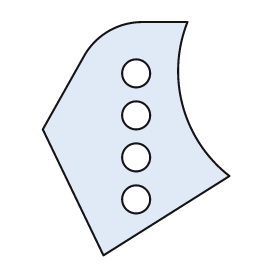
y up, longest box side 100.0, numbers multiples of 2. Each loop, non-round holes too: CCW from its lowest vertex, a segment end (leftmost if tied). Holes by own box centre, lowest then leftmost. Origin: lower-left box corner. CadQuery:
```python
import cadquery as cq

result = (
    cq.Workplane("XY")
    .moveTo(26.0, 0.0)
    .lineTo(80.0, 34.0)
    .threePointArc((60.0, 64.0), (62.0, 100.0))
    .lineTo(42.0, 100.0)
    .threePointArc((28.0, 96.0), (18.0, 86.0))
    .lineTo(0.0, 54.0)
    .close()
    .moveTo(40.0, 24.0)
    .circle(6.0)
    .moveTo(40.0, 42.0)
    .circle(6.0)
    .moveTo(40.0, 60.0)
    .circle(6.0)
    .moveTo(40.0, 78.0)
    .circle(6.0)
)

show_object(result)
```